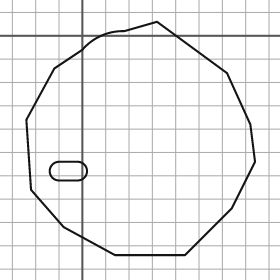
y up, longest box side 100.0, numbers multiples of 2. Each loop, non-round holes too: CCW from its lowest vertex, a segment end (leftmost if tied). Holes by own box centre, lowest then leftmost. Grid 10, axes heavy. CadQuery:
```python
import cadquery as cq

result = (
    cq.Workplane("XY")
    .moveTo(14.0, -94.0)
    .lineTo(44.0, -94.0)
    .lineTo(64.0, -74.0)
    .lineTo(74.0, -54.0)
    .lineTo(72.0, -38.0)
    .lineTo(62.0, -16.0)
    .lineTo(32.0, 6.0)
    .lineTo(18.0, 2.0)
    .threePointArc((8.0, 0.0), (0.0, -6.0))
    .lineTo(-12.0, -14.0)
    .lineTo(-24.0, -36.0)
    .lineTo(-22.0, -66.0)
    .lineTo(-8.0, -82.0)
    .close()
    .moveTo(-10.0, -62.0)
    .lineTo(-2.0, -62.0)
    .threePointArc((2.0, -58.0), (-2.0, -54.0))
    .lineTo(-10.0, -54.0)
    .threePointArc((-14.0, -58.0), (-10.0, -62.0))
    .close()
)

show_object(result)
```